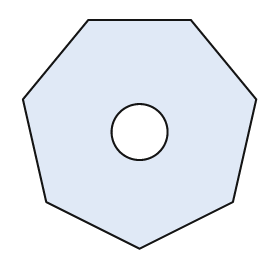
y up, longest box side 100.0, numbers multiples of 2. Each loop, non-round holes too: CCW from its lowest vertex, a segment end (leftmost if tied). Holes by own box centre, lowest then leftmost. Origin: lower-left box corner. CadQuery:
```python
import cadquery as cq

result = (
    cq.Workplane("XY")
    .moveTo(50.0, 0.0)
    .lineTo(90.0, 20.0)
    .lineTo(100.0, 64.0)
    .lineTo(72.0, 98.0)
    .lineTo(28.0, 98.0)
    .lineTo(0.0, 64.0)
    .lineTo(10.0, 20.0)
    .close()
    .moveTo(50.0, 50.0)
    .circle(12.0)
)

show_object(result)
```